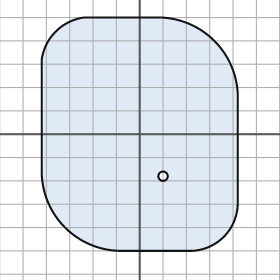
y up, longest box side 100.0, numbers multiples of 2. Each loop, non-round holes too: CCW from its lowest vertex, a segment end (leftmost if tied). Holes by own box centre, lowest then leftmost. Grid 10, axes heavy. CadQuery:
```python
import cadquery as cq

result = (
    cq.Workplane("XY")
    .moveTo(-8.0, -50.0)
    .lineTo(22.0, -50.0)
    .threePointArc((36.0, -44.0), (42.0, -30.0))
    .lineTo(42.0, 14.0)
    .threePointArc((32.0, 40.0), (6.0, 50.0))
    .lineTo(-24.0, 50.0)
    .threePointArc((-36.0, 44.0), (-42.0, 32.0))
    .lineTo(-42.0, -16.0)
    .threePointArc((-32.0, -40.0), (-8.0, -50.0))
    .close()
    .moveTo(10.0, -18.0)
    .circle(2.0)
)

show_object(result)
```